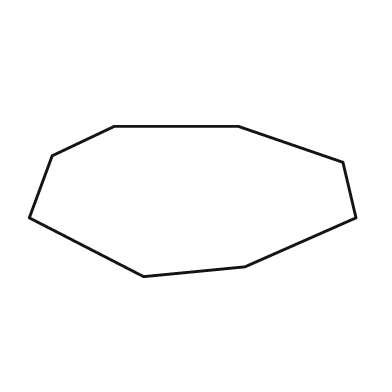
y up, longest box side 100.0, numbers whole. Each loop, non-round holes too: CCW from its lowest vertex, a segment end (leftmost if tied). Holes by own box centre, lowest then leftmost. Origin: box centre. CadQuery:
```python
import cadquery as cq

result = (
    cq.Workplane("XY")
    .moveTo(-15.0, -23.0)
    .lineTo(16.0, -20.0)
    .lineTo(50.0, -5.0)
    .lineTo(46.0, 12.0)
    .lineTo(14.0, 23.0)
    .lineTo(-24.0, 23.0)
    .lineTo(-43.0, 14.0)
    .lineTo(-50.0, -5.0)
    .close()
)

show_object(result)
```